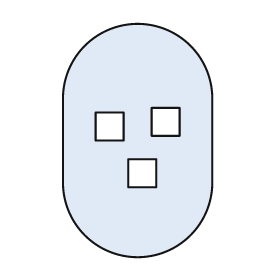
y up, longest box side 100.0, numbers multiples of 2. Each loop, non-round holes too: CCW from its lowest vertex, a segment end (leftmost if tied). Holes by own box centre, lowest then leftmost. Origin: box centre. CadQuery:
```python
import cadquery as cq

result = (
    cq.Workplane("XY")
    .moveTo(-32.0, -18.0)
    .threePointArc((0.0, -50.0), (32.0, -18.0))
    .lineTo(32.0, 18.0)
    .threePointArc((0.0, 50.0), (-32.0, 18.0))
    .close()
    .moveTo(-4.0, -20.0)
    .lineTo(8.0, -20.0)
    .lineTo(8.0, -8.0)
    .lineTo(-4.0, -8.0)
    .close()
    .moveTo(-18.0, 0.0)
    .lineTo(-6.0, 0.0)
    .lineTo(-6.0, 12.0)
    .lineTo(-18.0, 12.0)
    .close()
    .moveTo(6.0, 2.0)
    .lineTo(18.0, 2.0)
    .lineTo(18.0, 14.0)
    .lineTo(6.0, 14.0)
    .close()
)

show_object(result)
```